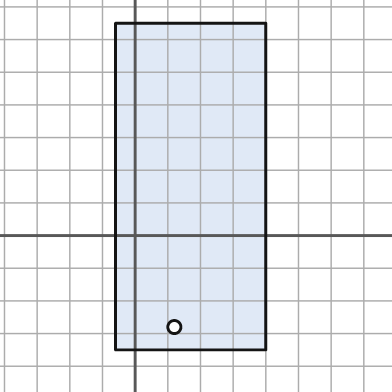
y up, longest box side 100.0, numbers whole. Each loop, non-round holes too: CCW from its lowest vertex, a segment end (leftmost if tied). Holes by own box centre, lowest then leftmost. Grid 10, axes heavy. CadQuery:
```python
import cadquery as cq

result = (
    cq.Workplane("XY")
    .moveTo(-6.0, -35.0)
    .lineTo(40.0, -35.0)
    .lineTo(40.0, 65.0)
    .lineTo(-6.0, 65.0)
    .close()
    .moveTo(12.0, -28.0)
    .circle(2.0)
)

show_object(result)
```